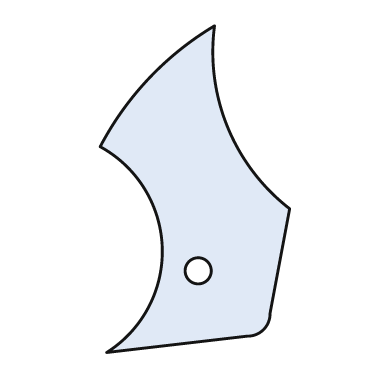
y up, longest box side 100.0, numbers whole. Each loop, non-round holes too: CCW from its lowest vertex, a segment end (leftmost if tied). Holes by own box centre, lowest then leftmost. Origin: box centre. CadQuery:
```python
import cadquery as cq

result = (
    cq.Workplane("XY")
    .moveTo(-27.0, -50.0)
    .lineTo(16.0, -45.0)
    .threePointArc((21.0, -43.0), (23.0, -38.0))
    .lineTo(29.0, -6.0)
    .threePointArc((10.0, 19.0), (6.0, 50.0))
    .threePointArc((-14.0, 34.0), (-29.0, 13.0))
    .threePointArc((-10.0, -18.0), (-27.0, -50.0))
    .close()
    .moveTo(1.0, -25.0)
    .circle(4.0)
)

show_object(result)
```